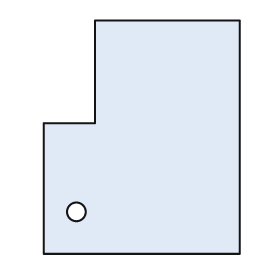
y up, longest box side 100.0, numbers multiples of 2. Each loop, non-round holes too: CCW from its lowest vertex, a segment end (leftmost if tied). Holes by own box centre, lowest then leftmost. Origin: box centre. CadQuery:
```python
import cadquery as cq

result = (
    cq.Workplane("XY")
    .moveTo(-42.0, -50.0)
    .lineTo(42.0, -50.0)
    .lineTo(42.0, 50.0)
    .lineTo(-20.0, 50.0)
    .lineTo(-20.0, 6.0)
    .lineTo(-42.0, 6.0)
    .close()
    .moveTo(-28.0, -32.0)
    .circle(4.0)
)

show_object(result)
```